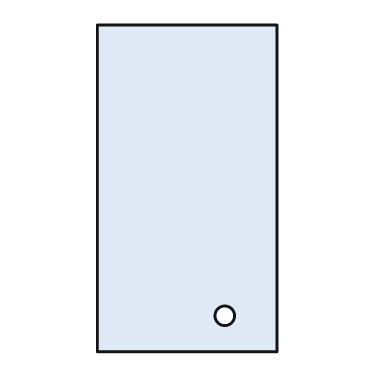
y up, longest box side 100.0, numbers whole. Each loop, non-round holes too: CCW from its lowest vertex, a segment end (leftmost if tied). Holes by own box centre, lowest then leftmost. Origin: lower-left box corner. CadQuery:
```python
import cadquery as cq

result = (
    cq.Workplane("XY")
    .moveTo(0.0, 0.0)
    .lineTo(55.0, 0.0)
    .lineTo(55.0, 100.0)
    .lineTo(0.0, 100.0)
    .close()
    .moveTo(39.0, 11.0)
    .circle(3.0)
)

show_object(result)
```